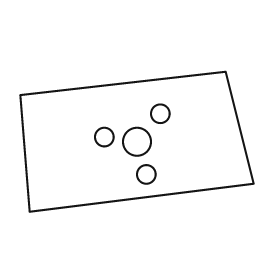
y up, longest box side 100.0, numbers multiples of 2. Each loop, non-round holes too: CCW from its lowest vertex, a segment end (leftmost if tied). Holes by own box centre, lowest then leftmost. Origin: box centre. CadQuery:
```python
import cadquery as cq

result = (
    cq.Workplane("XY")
    .moveTo(-46.0, -30.0)
    .lineTo(50.0, -18.0)
    .lineTo(38.0, 30.0)
    .lineTo(-50.0, 20.0)
    .close()
    .moveTo(4.0, -14.0)
    .circle(4.0)
    .moveTo(0.0, 0.0)
    .circle(6.0)
    .moveTo(-14.0, 2.0)
    .circle(4.0)
    .moveTo(10.0, 12.0)
    .circle(4.0)
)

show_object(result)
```